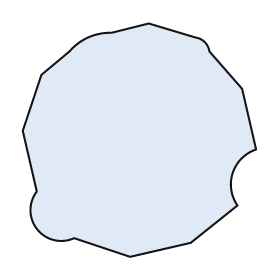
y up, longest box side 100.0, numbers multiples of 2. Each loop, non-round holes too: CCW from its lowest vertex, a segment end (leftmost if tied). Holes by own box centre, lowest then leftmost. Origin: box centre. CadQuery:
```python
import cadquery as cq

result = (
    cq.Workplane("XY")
    .moveTo(-4.0, -50.0)
    .lineTo(22.0, -44.0)
    .lineTo(42.0, -28.0)
    .threePointArc((40.0, -14.0), (50.0, -4.0))
    .lineTo(44.0, 22.0)
    .lineTo(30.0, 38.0)
    .threePointArc((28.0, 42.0), (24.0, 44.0))
    .lineTo(4.0, 50.0)
    .lineTo(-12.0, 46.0)
    .threePointArc((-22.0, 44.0), (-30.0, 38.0))
    .lineTo(-42.0, 28.0)
    .lineTo(-50.0, 4.0)
    .lineTo(-44.0, -22.0)
    .threePointArc((-44.0, -38.0), (-28.0, -42.0))
    .close()
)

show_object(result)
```